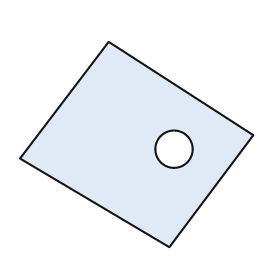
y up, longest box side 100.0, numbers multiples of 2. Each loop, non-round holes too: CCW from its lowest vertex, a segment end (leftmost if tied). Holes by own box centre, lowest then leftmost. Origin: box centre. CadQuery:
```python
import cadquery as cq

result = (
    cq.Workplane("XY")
    .moveTo(14.0, -44.0)
    .lineTo(50.0, 4.0)
    .lineTo(-12.0, 44.0)
    .lineTo(-50.0, -6.0)
    .close()
    .moveTo(16.0, -2.0)
    .circle(8.0)
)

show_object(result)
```